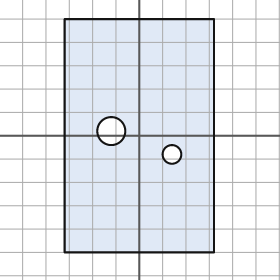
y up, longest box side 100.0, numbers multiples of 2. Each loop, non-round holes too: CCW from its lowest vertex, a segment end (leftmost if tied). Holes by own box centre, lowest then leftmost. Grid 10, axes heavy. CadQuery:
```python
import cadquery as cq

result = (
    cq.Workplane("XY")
    .moveTo(-32.0, -50.0)
    .lineTo(32.0, -50.0)
    .lineTo(32.0, 50.0)
    .lineTo(-32.0, 50.0)
    .close()
    .moveTo(14.0, -8.0)
    .circle(4.0)
    .moveTo(-12.0, 2.0)
    .circle(6.0)
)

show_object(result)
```